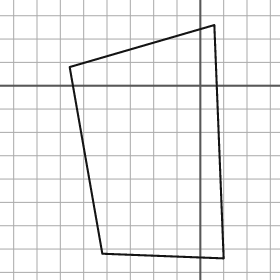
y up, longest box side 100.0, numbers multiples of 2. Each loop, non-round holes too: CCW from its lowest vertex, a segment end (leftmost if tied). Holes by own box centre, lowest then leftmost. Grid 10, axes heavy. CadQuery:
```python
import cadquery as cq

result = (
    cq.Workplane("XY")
    .moveTo(10.0, -74.0)
    .lineTo(6.0, 26.0)
    .lineTo(-56.0, 8.0)
    .lineTo(-42.0, -72.0)
    .close()
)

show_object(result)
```